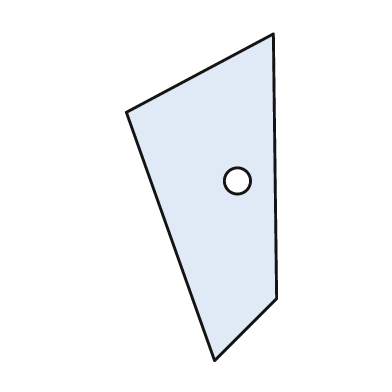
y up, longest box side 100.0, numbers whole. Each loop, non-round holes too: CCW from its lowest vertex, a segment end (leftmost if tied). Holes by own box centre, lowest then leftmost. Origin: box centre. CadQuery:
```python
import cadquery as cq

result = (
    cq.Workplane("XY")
    .moveTo(4.0, -50.0)
    .lineTo(23.0, -31.0)
    .lineTo(22.0, 50.0)
    .lineTo(-23.0, 26.0)
    .close()
    .moveTo(11.0, 5.0)
    .circle(4.0)
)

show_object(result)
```